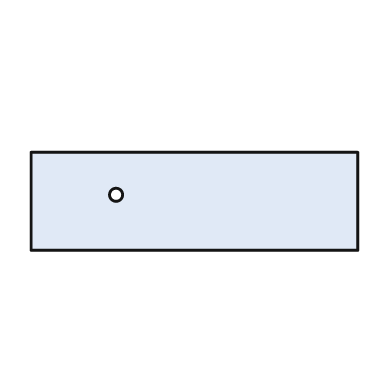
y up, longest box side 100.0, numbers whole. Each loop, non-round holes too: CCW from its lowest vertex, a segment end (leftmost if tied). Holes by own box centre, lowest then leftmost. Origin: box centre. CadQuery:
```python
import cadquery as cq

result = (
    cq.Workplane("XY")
    .moveTo(-50.0, -15.0)
    .lineTo(50.0, -15.0)
    .lineTo(50.0, 15.0)
    .lineTo(-50.0, 15.0)
    .close()
    .moveTo(-24.0, 2.0)
    .circle(2.0)
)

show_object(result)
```